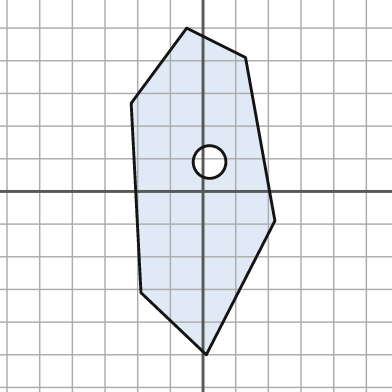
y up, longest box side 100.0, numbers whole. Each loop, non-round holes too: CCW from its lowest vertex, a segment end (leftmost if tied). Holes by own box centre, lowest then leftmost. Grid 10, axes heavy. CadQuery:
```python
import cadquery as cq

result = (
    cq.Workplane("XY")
    .moveTo(1.0, -50.0)
    .lineTo(22.0, -9.0)
    .lineTo(13.0, 41.0)
    .lineTo(-5.0, 50.0)
    .lineTo(-22.0, 27.0)
    .lineTo(-19.0, -31.0)
    .close()
    .moveTo(2.0, 9.0)
    .circle(5.0)
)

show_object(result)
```